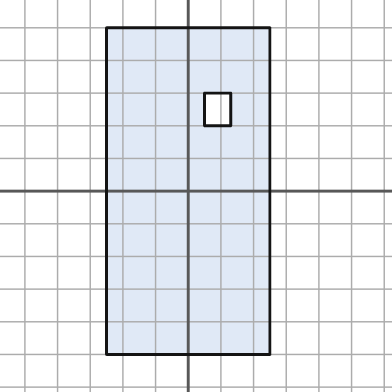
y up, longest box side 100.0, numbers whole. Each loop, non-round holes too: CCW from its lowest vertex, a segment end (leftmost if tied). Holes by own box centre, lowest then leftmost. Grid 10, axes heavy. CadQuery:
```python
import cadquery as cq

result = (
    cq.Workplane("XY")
    .moveTo(-25.0, -50.0)
    .lineTo(25.0, -50.0)
    .lineTo(25.0, 50.0)
    .lineTo(-25.0, 50.0)
    .close()
    .moveTo(5.0, 20.0)
    .lineTo(13.0, 20.0)
    .lineTo(13.0, 30.0)
    .lineTo(5.0, 30.0)
    .close()
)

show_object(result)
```